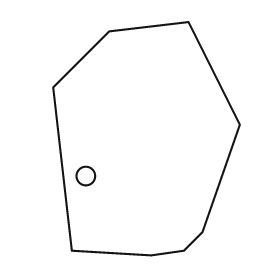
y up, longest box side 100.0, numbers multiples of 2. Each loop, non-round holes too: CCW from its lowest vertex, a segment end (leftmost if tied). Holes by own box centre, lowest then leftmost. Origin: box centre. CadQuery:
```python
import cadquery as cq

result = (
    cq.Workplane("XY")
    .moveTo(2.0, -50.0)
    .lineTo(16.0, -48.0)
    .lineTo(24.0, -40.0)
    .lineTo(40.0, 6.0)
    .lineTo(18.0, 50.0)
    .lineTo(-16.0, 46.0)
    .lineTo(-40.0, 22.0)
    .lineTo(-32.0, -48.0)
    .close()
    .moveTo(-26.0, -16.0)
    .circle(4.0)
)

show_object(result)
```